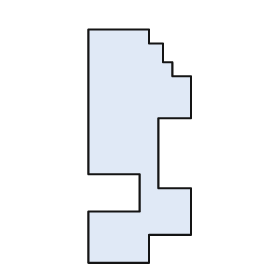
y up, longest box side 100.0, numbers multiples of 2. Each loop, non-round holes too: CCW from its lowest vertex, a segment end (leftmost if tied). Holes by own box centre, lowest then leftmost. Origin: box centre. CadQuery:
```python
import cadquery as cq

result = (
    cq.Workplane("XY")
    .moveTo(-22.0, -50.0)
    .lineTo(4.0, -50.0)
    .lineTo(4.0, -38.0)
    .lineTo(22.0, -38.0)
    .lineTo(22.0, -18.0)
    .lineTo(8.0, -18.0)
    .lineTo(8.0, 12.0)
    .lineTo(22.0, 12.0)
    .lineTo(22.0, 30.0)
    .lineTo(14.0, 30.0)
    .lineTo(14.0, 36.0)
    .lineTo(10.0, 36.0)
    .lineTo(10.0, 44.0)
    .lineTo(4.0, 44.0)
    .lineTo(4.0, 50.0)
    .lineTo(-22.0, 50.0)
    .lineTo(-22.0, -12.0)
    .lineTo(0.0, -12.0)
    .lineTo(0.0, -28.0)
    .lineTo(-22.0, -28.0)
    .close()
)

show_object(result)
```